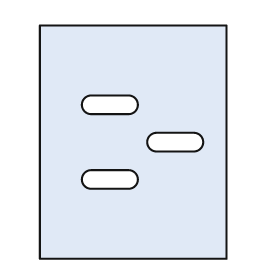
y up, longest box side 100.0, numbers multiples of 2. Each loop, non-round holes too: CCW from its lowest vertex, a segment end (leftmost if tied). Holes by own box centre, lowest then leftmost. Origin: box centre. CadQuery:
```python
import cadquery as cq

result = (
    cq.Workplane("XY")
    .moveTo(-40.0, -50.0)
    .lineTo(40.0, -50.0)
    .lineTo(40.0, 50.0)
    .lineTo(-40.0, 50.0)
    .close()
    .moveTo(-18.0, -20.0)
    .lineTo(-2.0, -20.0)
    .threePointArc((2.0, -16.0), (-2.0, -12.0))
    .lineTo(-18.0, -12.0)
    .threePointArc((-22.0, -16.0), (-18.0, -20.0))
    .close()
    .moveTo(10.0, -4.0)
    .lineTo(26.0, -4.0)
    .threePointArc((30.0, 0.0), (26.0, 4.0))
    .lineTo(10.0, 4.0)
    .threePointArc((6.0, 0.0), (10.0, -4.0))
    .close()
    .moveTo(-18.0, 12.0)
    .lineTo(-2.0, 12.0)
    .threePointArc((2.0, 16.0), (-2.0, 20.0))
    .lineTo(-18.0, 20.0)
    .threePointArc((-22.0, 16.0), (-18.0, 12.0))
    .close()
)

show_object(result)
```